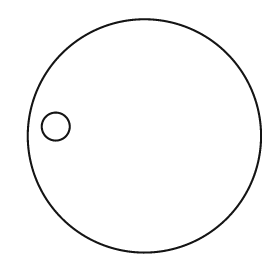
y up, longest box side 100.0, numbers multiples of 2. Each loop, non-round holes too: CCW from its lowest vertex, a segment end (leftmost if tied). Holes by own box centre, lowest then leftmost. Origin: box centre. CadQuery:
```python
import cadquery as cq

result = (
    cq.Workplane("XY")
    .moveTo(0.0, 0.0)
    .circle(50.0)
    .moveTo(-38.0, 4.0)
    .circle(6.0)
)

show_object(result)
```